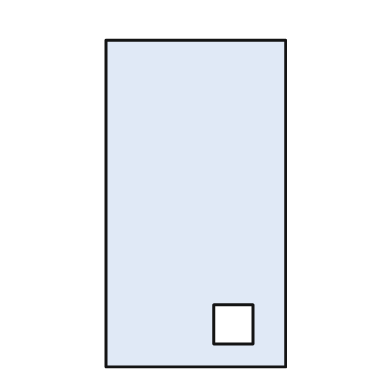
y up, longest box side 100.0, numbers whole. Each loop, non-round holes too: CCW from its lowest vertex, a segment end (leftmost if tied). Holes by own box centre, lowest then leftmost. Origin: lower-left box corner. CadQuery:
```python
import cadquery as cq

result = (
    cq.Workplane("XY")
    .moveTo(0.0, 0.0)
    .lineTo(55.0, 0.0)
    .lineTo(55.0, 100.0)
    .lineTo(0.0, 100.0)
    .close()
    .moveTo(33.0, 7.0)
    .lineTo(45.0, 7.0)
    .lineTo(45.0, 19.0)
    .lineTo(33.0, 19.0)
    .close()
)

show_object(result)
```